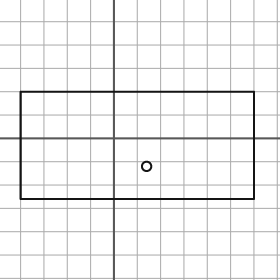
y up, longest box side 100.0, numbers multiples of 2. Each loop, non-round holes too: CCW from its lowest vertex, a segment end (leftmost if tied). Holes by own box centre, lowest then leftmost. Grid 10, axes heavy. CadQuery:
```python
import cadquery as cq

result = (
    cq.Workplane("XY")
    .moveTo(-40.0, -26.0)
    .lineTo(60.0, -26.0)
    .lineTo(60.0, 20.0)
    .lineTo(-40.0, 20.0)
    .close()
    .moveTo(14.0, -12.0)
    .circle(2.0)
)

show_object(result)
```